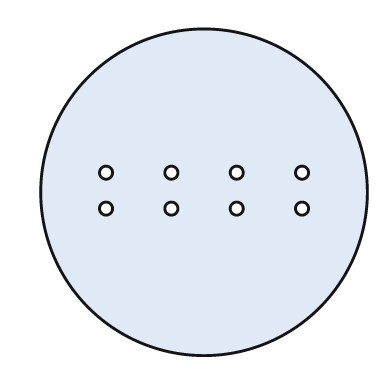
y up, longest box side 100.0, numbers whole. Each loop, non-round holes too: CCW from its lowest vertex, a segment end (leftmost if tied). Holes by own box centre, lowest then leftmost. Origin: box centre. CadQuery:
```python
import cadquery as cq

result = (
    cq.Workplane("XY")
    .moveTo(0.0, 0.0)
    .circle(50.0)
    .moveTo(-30.0, -5.0)
    .circle(2.0)
    .moveTo(-10.0, -5.0)
    .circle(2.0)
    .moveTo(10.0, -5.0)
    .circle(2.0)
    .moveTo(30.0, -5.0)
    .circle(2.0)
    .moveTo(-30.0, 6.0)
    .circle(2.0)
    .moveTo(-10.0, 6.0)
    .circle(2.0)
    .moveTo(10.0, 6.0)
    .circle(2.0)
    .moveTo(30.0, 6.0)
    .circle(2.0)
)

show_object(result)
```